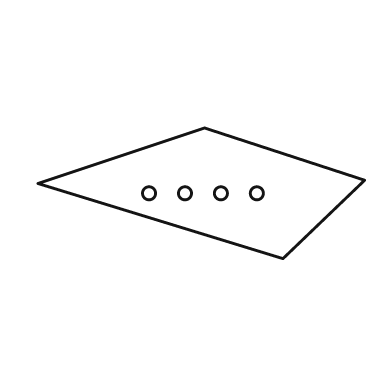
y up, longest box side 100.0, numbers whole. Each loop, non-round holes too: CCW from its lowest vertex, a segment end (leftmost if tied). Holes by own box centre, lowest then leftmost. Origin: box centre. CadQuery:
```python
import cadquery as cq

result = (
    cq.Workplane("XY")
    .moveTo(25.0, -20.0)
    .lineTo(50.0, 4.0)
    .lineTo(1.0, 20.0)
    .lineTo(-50.0, 3.0)
    .close()
    .moveTo(-16.0, 0.0)
    .circle(2.0)
    .moveTo(-5.0, 0.0)
    .circle(2.0)
    .moveTo(6.0, 0.0)
    .circle(2.0)
    .moveTo(17.0, 0.0)
    .circle(2.0)
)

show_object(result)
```